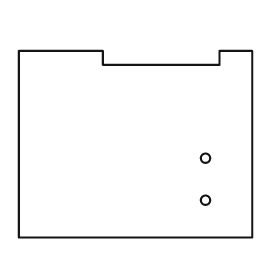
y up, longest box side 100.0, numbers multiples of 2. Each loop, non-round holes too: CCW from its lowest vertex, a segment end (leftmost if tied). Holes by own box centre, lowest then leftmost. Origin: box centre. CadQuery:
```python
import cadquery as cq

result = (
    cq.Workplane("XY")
    .moveTo(-50.0, -40.0)
    .lineTo(50.0, -40.0)
    .lineTo(50.0, 40.0)
    .lineTo(36.0, 40.0)
    .lineTo(36.0, 34.0)
    .lineTo(-14.0, 34.0)
    .lineTo(-14.0, 40.0)
    .lineTo(-50.0, 40.0)
    .close()
    .moveTo(30.0, -24.0)
    .circle(2.0)
    .moveTo(30.0, -6.0)
    .circle(2.0)
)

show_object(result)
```